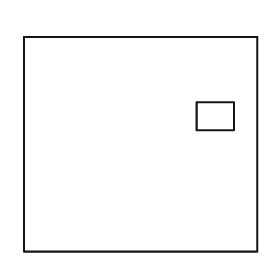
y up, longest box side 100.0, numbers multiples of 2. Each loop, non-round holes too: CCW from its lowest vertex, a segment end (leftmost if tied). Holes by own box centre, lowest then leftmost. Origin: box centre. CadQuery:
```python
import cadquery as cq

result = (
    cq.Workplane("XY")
    .moveTo(-50.0, -46.0)
    .lineTo(50.0, -46.0)
    .lineTo(50.0, 46.0)
    .lineTo(-50.0, 46.0)
    .close()
    .moveTo(24.0, 6.0)
    .lineTo(40.0, 6.0)
    .lineTo(40.0, 18.0)
    .lineTo(24.0, 18.0)
    .close()
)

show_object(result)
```